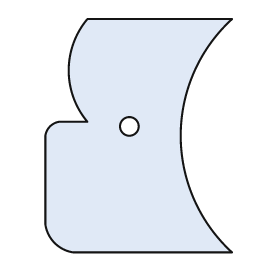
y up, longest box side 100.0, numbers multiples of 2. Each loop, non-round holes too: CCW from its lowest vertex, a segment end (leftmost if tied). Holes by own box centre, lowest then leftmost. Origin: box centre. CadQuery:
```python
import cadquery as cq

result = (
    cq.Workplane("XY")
    .moveTo(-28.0, -50.0)
    .lineTo(40.0, -50.0)
    .threePointArc((18.0, 0.0), (40.0, 50.0))
    .lineTo(-22.0, 50.0)
    .threePointArc((-30.0, 28.0), (-22.0, 6.0))
    .lineTo(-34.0, 6.0)
    .threePointArc((-38.0, 4.0), (-40.0, 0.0))
    .lineTo(-40.0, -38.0)
    .threePointArc((-36.0, -46.0), (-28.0, -50.0))
    .close()
    .moveTo(-4.0, 4.0)
    .circle(4.0)
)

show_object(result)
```